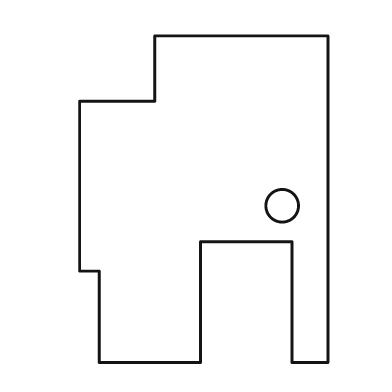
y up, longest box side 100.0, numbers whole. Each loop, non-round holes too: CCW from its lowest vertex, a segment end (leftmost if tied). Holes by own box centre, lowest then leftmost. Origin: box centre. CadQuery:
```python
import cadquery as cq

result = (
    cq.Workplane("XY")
    .moveTo(-32.0, -50.0)
    .lineTo(-1.0, -50.0)
    .lineTo(-1.0, -13.0)
    .lineTo(27.0, -13.0)
    .lineTo(27.0, -50.0)
    .lineTo(38.0, -50.0)
    .lineTo(38.0, 50.0)
    .lineTo(-15.0, 50.0)
    .lineTo(-15.0, 30.0)
    .lineTo(-38.0, 30.0)
    .lineTo(-38.0, -22.0)
    .lineTo(-32.0, -22.0)
    .close()
    .moveTo(24.0, -2.0)
    .circle(5.0)
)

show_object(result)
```